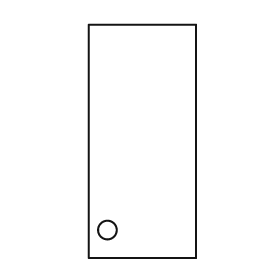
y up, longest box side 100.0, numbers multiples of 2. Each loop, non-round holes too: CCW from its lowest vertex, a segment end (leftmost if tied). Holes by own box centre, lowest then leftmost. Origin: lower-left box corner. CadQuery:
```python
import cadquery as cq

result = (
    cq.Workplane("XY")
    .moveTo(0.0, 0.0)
    .lineTo(46.0, 0.0)
    .lineTo(46.0, 100.0)
    .lineTo(0.0, 100.0)
    .close()
    .moveTo(8.0, 12.0)
    .circle(4.0)
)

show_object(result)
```